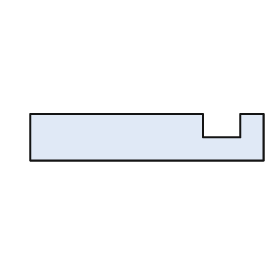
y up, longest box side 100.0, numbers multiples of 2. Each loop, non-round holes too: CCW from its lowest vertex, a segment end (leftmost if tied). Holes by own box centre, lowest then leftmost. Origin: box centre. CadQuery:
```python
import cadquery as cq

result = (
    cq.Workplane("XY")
    .moveTo(-50.0, -10.0)
    .lineTo(50.0, -10.0)
    .lineTo(50.0, 10.0)
    .lineTo(40.0, 10.0)
    .lineTo(40.0, 0.0)
    .lineTo(24.0, 0.0)
    .lineTo(24.0, 10.0)
    .lineTo(-50.0, 10.0)
    .close()
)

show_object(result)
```